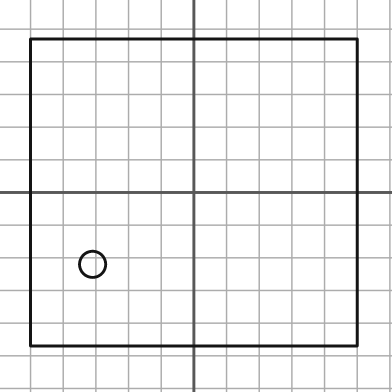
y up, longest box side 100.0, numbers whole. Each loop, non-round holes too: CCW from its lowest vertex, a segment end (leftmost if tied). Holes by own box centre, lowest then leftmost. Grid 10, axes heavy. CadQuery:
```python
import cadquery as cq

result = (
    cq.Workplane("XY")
    .moveTo(-50.0, -47.0)
    .lineTo(50.0, -47.0)
    .lineTo(50.0, 47.0)
    .lineTo(-50.0, 47.0)
    .close()
    .moveTo(-31.0, -22.0)
    .circle(4.0)
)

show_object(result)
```